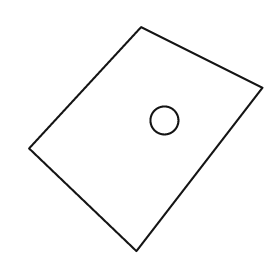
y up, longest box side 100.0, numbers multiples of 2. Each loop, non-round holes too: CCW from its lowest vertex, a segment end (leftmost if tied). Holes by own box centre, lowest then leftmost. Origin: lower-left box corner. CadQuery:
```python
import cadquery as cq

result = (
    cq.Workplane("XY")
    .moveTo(46.0, 0.0)
    .lineTo(100.0, 70.0)
    .lineTo(48.0, 96.0)
    .lineTo(0.0, 44.0)
    .close()
    .moveTo(58.0, 56.0)
    .circle(6.0)
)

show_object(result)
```